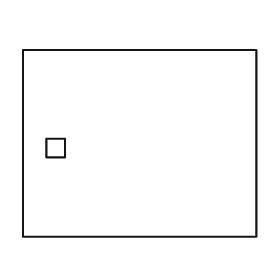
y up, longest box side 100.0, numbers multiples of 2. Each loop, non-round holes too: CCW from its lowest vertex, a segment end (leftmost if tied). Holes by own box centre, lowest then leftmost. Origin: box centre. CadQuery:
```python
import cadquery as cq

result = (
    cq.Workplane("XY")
    .moveTo(-50.0, -40.0)
    .lineTo(50.0, -40.0)
    .lineTo(50.0, 40.0)
    .lineTo(-50.0, 40.0)
    .close()
    .moveTo(-40.0, -6.0)
    .lineTo(-32.0, -6.0)
    .lineTo(-32.0, 2.0)
    .lineTo(-40.0, 2.0)
    .close()
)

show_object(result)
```